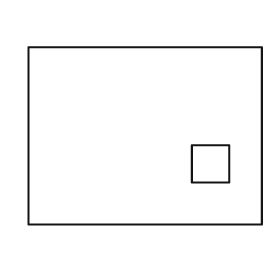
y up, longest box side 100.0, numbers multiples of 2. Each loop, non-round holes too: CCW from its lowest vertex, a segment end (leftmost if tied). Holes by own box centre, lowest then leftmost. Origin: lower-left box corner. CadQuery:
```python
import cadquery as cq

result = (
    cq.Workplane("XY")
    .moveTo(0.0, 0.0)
    .lineTo(100.0, 0.0)
    .lineTo(100.0, 76.0)
    .lineTo(0.0, 76.0)
    .close()
    .moveTo(70.0, 18.0)
    .lineTo(86.0, 18.0)
    .lineTo(86.0, 34.0)
    .lineTo(70.0, 34.0)
    .close()
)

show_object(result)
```